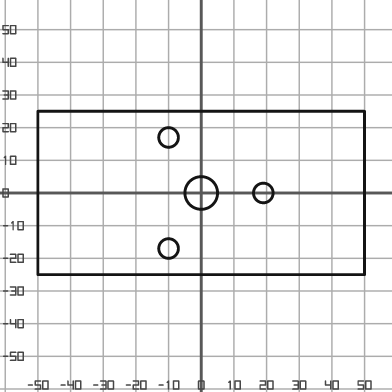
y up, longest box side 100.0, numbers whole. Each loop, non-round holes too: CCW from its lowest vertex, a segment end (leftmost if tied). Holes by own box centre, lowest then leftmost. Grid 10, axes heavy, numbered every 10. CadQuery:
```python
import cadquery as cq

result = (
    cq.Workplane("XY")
    .moveTo(-50.0, -25.0)
    .lineTo(50.0, -25.0)
    .lineTo(50.0, 25.0)
    .lineTo(-50.0, 25.0)
    .close()
    .moveTo(-10.0, -17.0)
    .circle(3.0)
    .moveTo(0.0, 0.0)
    .circle(5.0)
    .moveTo(19.0, 0.0)
    .circle(3.0)
    .moveTo(-10.0, 17.0)
    .circle(3.0)
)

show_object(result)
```